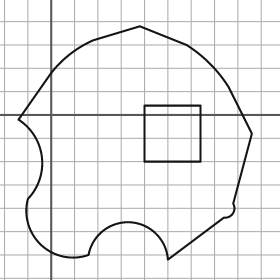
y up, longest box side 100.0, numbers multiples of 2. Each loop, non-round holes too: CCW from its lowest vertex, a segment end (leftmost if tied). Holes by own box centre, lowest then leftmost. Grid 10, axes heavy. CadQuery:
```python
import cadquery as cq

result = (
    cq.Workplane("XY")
    .moveTo(50.0, -62.0)
    .lineTo(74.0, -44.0)
    .threePointArc((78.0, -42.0), (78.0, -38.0))
    .lineTo(86.0, -8.0)
    .lineTo(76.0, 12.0)
    .threePointArc((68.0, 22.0), (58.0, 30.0))
    .lineTo(38.0, 38.0)
    .lineTo(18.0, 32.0)
    .threePointArc((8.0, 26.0), (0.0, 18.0))
    .lineTo(-14.0, -2.0)
    .threePointArc((-4.0, -18.0), (-10.0, -36.0))
    .threePointArc((-4.0, -56.0), (16.0, -60.0))
    .threePointArc((34.0, -46.0), (50.0, -62.0))
    .close()
    .moveTo(40.0, -20.0)
    .lineTo(64.0, -20.0)
    .lineTo(64.0, 4.0)
    .lineTo(40.0, 4.0)
    .close()
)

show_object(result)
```